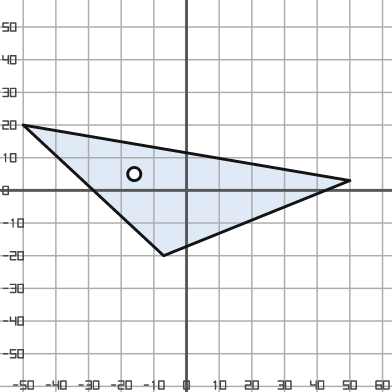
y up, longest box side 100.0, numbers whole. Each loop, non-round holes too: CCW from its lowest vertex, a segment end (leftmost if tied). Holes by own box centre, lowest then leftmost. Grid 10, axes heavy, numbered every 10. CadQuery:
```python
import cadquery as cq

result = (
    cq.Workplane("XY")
    .moveTo(-7.0, -20.0)
    .lineTo(50.0, 3.0)
    .lineTo(-50.0, 20.0)
    .close()
    .moveTo(-16.0, 5.0)
    .circle(2.0)
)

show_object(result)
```